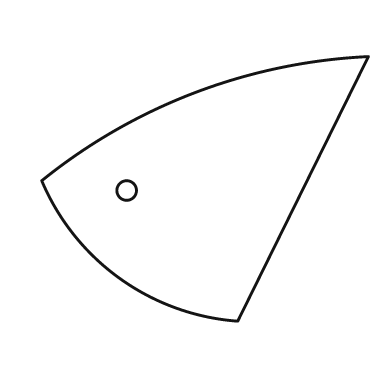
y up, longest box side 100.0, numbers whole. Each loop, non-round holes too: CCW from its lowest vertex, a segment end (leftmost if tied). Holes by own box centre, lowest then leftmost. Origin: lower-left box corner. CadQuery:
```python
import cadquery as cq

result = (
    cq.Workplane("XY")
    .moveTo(60.0, 0.0)
    .lineTo(100.0, 81.0)
    .threePointArc((47.0, 70.0), (0.0, 43.0))
    .threePointArc((24.0, 13.0), (60.0, 0.0))
    .close()
    .moveTo(26.0, 40.0)
    .circle(3.0)
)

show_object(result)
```